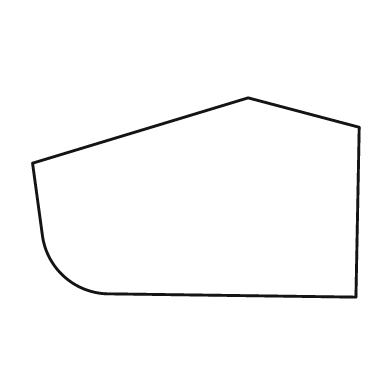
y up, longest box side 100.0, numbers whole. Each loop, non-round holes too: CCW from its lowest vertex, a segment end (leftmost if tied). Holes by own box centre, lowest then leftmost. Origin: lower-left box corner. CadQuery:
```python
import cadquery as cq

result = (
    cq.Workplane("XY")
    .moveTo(99.0, 0.0)
    .lineTo(100.0, 52.0)
    .lineTo(66.0, 61.0)
    .lineTo(0.0, 41.0)
    .lineTo(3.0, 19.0)
    .threePointArc((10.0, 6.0), (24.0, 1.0))
    .close()
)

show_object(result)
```